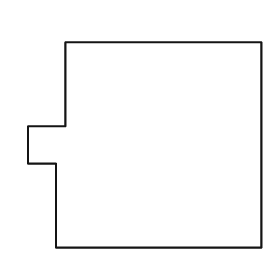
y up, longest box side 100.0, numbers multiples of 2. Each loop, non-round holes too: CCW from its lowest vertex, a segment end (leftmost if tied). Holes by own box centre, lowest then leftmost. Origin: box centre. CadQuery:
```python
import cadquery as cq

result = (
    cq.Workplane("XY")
    .moveTo(-38.0, -44.0)
    .lineTo(50.0, -44.0)
    .lineTo(50.0, 44.0)
    .lineTo(-34.0, 44.0)
    .lineTo(-34.0, 8.0)
    .lineTo(-50.0, 8.0)
    .lineTo(-50.0, -8.0)
    .lineTo(-38.0, -8.0)
    .close()
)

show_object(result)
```